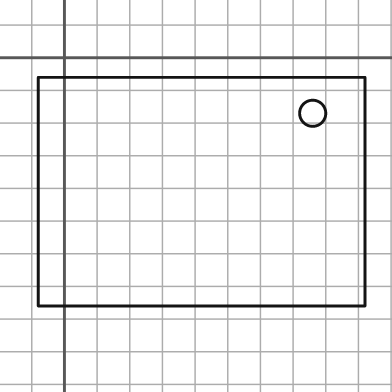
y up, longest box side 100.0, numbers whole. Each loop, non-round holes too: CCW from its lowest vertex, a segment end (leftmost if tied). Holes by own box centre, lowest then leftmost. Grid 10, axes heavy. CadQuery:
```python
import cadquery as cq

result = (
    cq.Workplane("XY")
    .moveTo(-8.0, -76.0)
    .lineTo(92.0, -76.0)
    .lineTo(92.0, -6.0)
    .lineTo(-8.0, -6.0)
    .close()
    .moveTo(76.0, -17.0)
    .circle(4.0)
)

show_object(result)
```